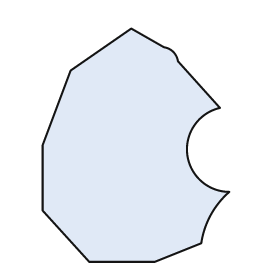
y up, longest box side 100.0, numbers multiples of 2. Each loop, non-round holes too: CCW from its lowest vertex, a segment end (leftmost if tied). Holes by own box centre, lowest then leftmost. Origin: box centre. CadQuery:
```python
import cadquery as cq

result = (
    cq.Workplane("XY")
    .moveTo(-20.0, -50.0)
    .lineTo(8.0, -50.0)
    .lineTo(28.0, -42.0)
    .threePointArc((32.0, -30.0), (40.0, -20.0))
    .threePointArc((22.0, -4.0), (36.0, 16.0))
    .lineTo(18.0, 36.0)
    .threePointArc((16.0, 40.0), (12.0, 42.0))
    .lineTo(-2.0, 50.0)
    .lineTo(-28.0, 32.0)
    .lineTo(-40.0, 0.0)
    .lineTo(-40.0, -28.0)
    .close()
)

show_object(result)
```